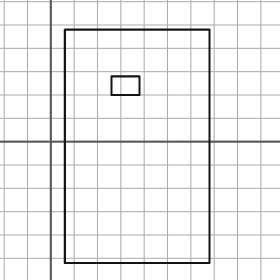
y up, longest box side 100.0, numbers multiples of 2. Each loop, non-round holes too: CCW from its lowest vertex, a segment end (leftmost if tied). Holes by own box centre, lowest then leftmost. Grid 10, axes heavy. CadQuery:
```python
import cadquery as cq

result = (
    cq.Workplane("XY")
    .moveTo(6.0, -52.0)
    .lineTo(68.0, -52.0)
    .lineTo(68.0, 48.0)
    .lineTo(6.0, 48.0)
    .close()
    .moveTo(26.0, 20.0)
    .lineTo(38.0, 20.0)
    .lineTo(38.0, 28.0)
    .lineTo(26.0, 28.0)
    .close()
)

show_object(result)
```